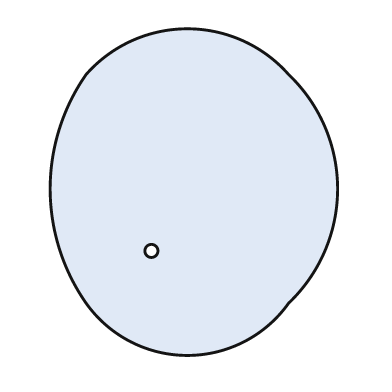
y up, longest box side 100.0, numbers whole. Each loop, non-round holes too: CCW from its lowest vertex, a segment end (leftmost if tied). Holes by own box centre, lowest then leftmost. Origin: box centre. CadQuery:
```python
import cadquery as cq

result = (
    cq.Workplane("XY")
    .moveTo(-33.0, -34.0)
    .threePointArc((-2.0, -50.0), (29.0, -34.0))
    .threePointArc((44.0, 1.0), (29.0, 36.0))
    .threePointArc((-2.0, 50.0), (-33.0, 36.0))
    .threePointArc((-44.0, 1.0), (-33.0, -34.0))
    .close()
    .moveTo(-13.0, -18.0)
    .circle(2.0)
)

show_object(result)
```